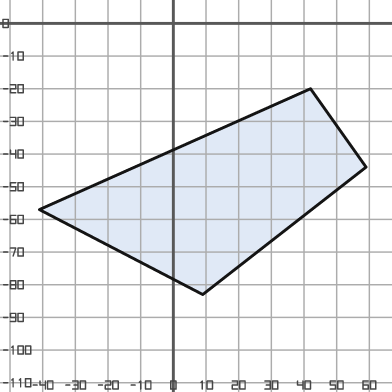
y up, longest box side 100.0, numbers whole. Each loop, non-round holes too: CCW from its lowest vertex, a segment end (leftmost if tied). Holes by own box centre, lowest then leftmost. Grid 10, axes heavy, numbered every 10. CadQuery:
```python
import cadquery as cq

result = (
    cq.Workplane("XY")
    .moveTo(9.0, -83.0)
    .lineTo(59.0, -44.0)
    .lineTo(42.0, -20.0)
    .lineTo(-41.0, -57.0)
    .close()
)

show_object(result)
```